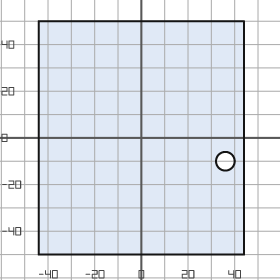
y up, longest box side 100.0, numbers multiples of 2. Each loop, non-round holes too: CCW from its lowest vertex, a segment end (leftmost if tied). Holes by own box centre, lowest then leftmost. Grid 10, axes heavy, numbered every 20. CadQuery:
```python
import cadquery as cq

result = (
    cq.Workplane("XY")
    .moveTo(-44.0, -50.0)
    .lineTo(44.0, -50.0)
    .lineTo(44.0, 50.0)
    .lineTo(-44.0, 50.0)
    .close()
    .moveTo(36.0, -10.0)
    .circle(4.0)
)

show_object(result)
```